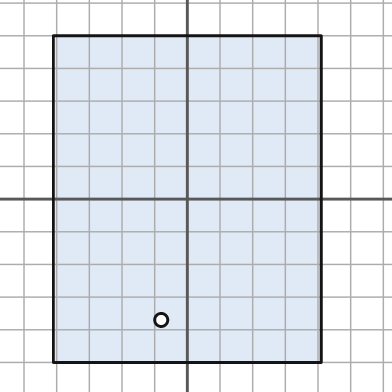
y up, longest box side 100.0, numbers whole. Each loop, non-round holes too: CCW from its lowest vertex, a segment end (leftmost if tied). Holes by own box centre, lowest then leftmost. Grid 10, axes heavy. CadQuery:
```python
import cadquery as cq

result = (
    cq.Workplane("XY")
    .moveTo(-41.0, -50.0)
    .lineTo(41.0, -50.0)
    .lineTo(41.0, 50.0)
    .lineTo(-41.0, 50.0)
    .close()
    .moveTo(-8.0, -37.0)
    .circle(2.0)
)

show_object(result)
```